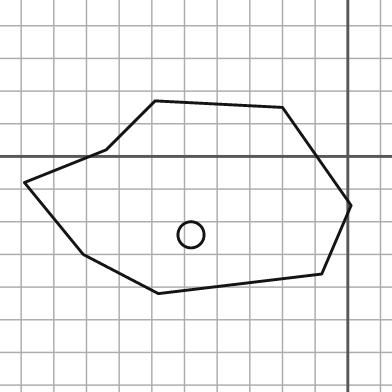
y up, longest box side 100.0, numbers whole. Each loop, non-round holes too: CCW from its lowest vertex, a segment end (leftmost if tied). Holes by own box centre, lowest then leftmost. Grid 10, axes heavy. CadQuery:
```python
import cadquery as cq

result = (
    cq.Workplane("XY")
    .moveTo(-58.0, -42.0)
    .lineTo(-8.0, -36.0)
    .lineTo(1.0, -15.0)
    .lineTo(-20.0, 15.0)
    .lineTo(-59.0, 17.0)
    .lineTo(-74.0, 2.0)
    .lineTo(-99.0, -8.0)
    .lineTo(-81.0, -30.0)
    .close()
    .moveTo(-48.0, -24.0)
    .circle(4.0)
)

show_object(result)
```